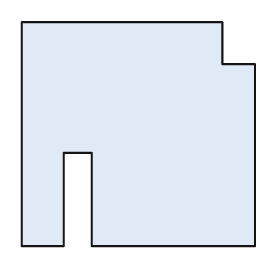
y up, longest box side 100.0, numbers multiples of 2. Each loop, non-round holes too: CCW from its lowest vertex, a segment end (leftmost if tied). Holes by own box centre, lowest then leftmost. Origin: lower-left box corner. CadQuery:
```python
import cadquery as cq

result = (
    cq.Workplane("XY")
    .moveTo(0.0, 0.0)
    .lineTo(18.0, 0.0)
    .lineTo(18.0, 40.0)
    .lineTo(30.0, 40.0)
    .lineTo(30.0, 0.0)
    .lineTo(100.0, 0.0)
    .lineTo(100.0, 78.0)
    .lineTo(86.0, 78.0)
    .lineTo(86.0, 96.0)
    .lineTo(0.0, 96.0)
    .close()
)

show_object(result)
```